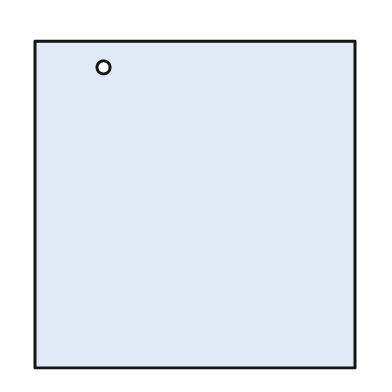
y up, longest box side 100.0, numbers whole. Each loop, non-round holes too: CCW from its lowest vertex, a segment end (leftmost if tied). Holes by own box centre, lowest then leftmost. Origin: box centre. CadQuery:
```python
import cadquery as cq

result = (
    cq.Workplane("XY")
    .moveTo(-49.0, -50.0)
    .lineTo(49.0, -50.0)
    .lineTo(49.0, 50.0)
    .lineTo(-49.0, 50.0)
    .close()
    .moveTo(-28.0, 42.0)
    .circle(2.0)
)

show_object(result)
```